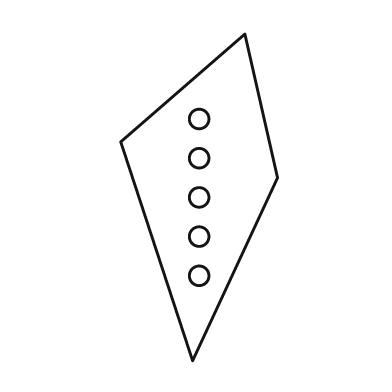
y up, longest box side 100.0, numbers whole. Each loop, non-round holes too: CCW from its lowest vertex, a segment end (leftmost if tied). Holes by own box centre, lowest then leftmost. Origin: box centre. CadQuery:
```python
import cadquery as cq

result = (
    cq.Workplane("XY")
    .moveTo(-2.0, -50.0)
    .lineTo(24.0, 6.0)
    .lineTo(14.0, 50.0)
    .lineTo(-24.0, 17.0)
    .close()
    .moveTo(0.0, -24.0)
    .circle(3.0)
    .moveTo(0.0, -12.0)
    .circle(3.0)
    .moveTo(0.0, 0.0)
    .circle(3.0)
    .moveTo(0.0, 12.0)
    .circle(3.0)
    .moveTo(0.0, 24.0)
    .circle(3.0)
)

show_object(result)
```